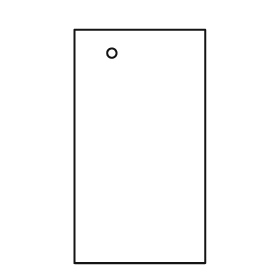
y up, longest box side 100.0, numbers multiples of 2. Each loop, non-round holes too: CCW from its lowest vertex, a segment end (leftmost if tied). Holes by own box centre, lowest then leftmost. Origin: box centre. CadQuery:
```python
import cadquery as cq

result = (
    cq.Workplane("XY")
    .moveTo(-28.0, -50.0)
    .lineTo(28.0, -50.0)
    .lineTo(28.0, 50.0)
    .lineTo(-28.0, 50.0)
    .close()
    .moveTo(-12.0, 40.0)
    .circle(2.0)
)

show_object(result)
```